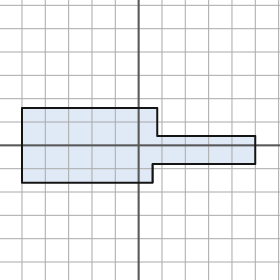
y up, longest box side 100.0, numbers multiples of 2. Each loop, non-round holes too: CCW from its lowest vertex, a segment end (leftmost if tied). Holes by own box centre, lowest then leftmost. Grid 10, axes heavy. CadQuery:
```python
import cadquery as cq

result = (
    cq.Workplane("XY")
    .moveTo(-50.0, -16.0)
    .lineTo(6.0, -16.0)
    .lineTo(6.0, -8.0)
    .lineTo(50.0, -8.0)
    .lineTo(50.0, 4.0)
    .lineTo(8.0, 4.0)
    .lineTo(8.0, 16.0)
    .lineTo(-50.0, 16.0)
    .close()
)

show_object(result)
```